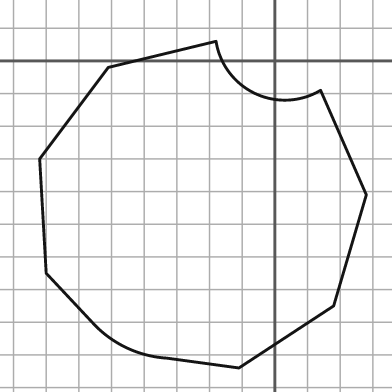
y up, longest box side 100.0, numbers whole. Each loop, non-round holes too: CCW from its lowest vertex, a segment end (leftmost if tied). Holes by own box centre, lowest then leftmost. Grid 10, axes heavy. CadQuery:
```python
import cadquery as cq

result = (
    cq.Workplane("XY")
    .moveTo(-11.0, -94.0)
    .lineTo(18.0, -75.0)
    .lineTo(28.0, -41.0)
    .lineTo(14.0, -9.0)
    .threePointArc((-6.0, -10.0), (-18.0, 6.0))
    .lineTo(-51.0, -2.0)
    .lineTo(-72.0, -30.0)
    .lineTo(-70.0, -65.0)
    .lineTo(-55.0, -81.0)
    .threePointArc((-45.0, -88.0), (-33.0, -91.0))
    .close()
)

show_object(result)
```